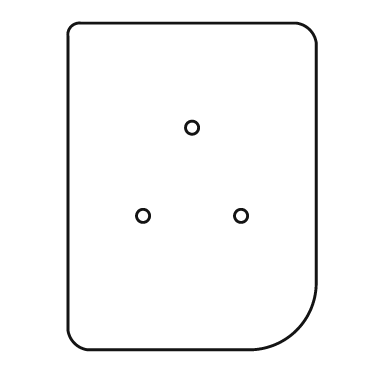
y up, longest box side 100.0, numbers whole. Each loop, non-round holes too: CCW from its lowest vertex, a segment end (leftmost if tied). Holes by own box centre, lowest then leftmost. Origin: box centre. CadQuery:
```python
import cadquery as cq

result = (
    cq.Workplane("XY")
    .moveTo(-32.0, -50.0)
    .lineTo(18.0, -50.0)
    .threePointArc((32.0, -44.0), (38.0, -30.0))
    .lineTo(38.0, 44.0)
    .threePointArc((36.0, 48.0), (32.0, 50.0))
    .lineTo(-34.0, 50.0)
    .threePointArc((-37.0, 49.0), (-38.0, 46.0))
    .lineTo(-38.0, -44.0)
    .threePointArc((-36.0, -48.0), (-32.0, -50.0))
    .close()
    .moveTo(-15.0, -9.0)
    .circle(2.0)
    .moveTo(15.0, -9.0)
    .circle(2.0)
    .moveTo(0.0, 18.0)
    .circle(2.0)
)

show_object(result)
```